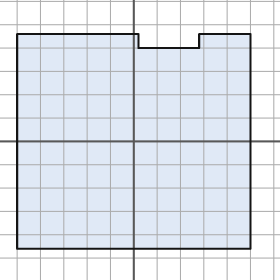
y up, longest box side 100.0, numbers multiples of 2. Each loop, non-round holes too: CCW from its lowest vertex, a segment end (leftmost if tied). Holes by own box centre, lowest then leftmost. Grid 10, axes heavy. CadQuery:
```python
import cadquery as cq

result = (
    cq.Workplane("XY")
    .moveTo(-50.0, -46.0)
    .lineTo(50.0, -46.0)
    .lineTo(50.0, 46.0)
    .lineTo(28.0, 46.0)
    .lineTo(28.0, 40.0)
    .lineTo(2.0, 40.0)
    .lineTo(2.0, 46.0)
    .lineTo(-50.0, 46.0)
    .close()
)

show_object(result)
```